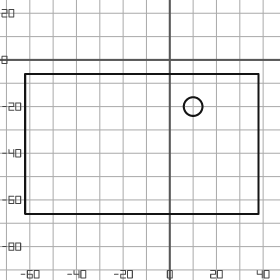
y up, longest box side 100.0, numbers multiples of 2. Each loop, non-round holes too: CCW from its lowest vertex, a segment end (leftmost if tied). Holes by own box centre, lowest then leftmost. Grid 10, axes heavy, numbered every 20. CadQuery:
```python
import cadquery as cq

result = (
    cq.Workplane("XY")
    .moveTo(-62.0, -66.0)
    .lineTo(38.0, -66.0)
    .lineTo(38.0, -6.0)
    .lineTo(-62.0, -6.0)
    .close()
    .moveTo(10.0, -20.0)
    .circle(4.0)
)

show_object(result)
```